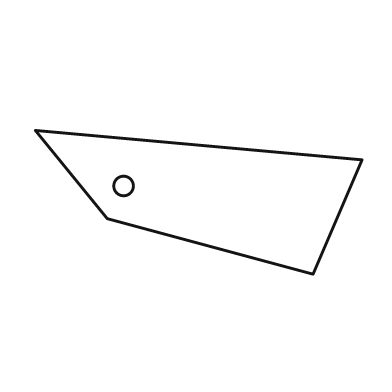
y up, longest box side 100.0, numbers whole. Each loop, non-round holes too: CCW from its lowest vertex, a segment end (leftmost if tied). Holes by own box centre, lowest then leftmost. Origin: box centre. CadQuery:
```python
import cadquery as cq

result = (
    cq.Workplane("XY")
    .moveTo(35.0, -22.0)
    .lineTo(50.0, 13.0)
    .lineTo(-50.0, 22.0)
    .lineTo(-28.0, -5.0)
    .close()
    .moveTo(-23.0, 5.0)
    .circle(3.0)
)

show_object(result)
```